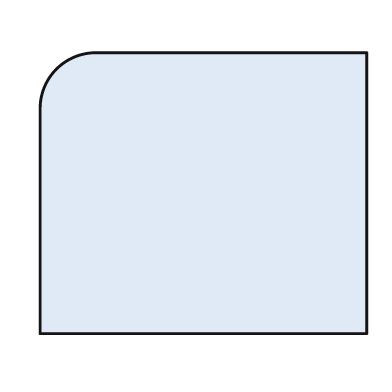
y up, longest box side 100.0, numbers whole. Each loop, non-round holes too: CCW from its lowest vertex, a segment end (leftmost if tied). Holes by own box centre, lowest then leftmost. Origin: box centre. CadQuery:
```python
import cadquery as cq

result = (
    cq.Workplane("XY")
    .moveTo(-50.0, -43.0)
    .lineTo(50.0, -43.0)
    .lineTo(50.0, 43.0)
    .lineTo(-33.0, 43.0)
    .threePointArc((-45.0, 38.0), (-50.0, 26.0))
    .close()
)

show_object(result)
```